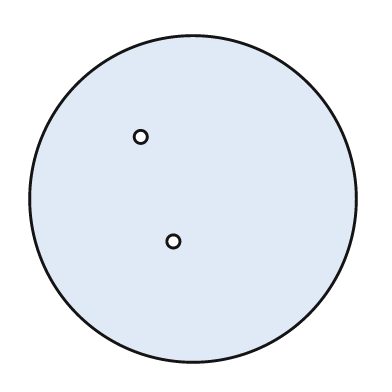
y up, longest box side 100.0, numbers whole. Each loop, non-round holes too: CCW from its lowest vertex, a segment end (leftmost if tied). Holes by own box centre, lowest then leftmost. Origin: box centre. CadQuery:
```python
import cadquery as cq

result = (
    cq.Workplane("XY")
    .moveTo(0.0, 0.0)
    .circle(50.0)
    .moveTo(-6.0, -13.0)
    .circle(2.0)
    .moveTo(-16.0, 19.0)
    .circle(2.0)
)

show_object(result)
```